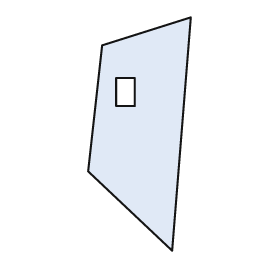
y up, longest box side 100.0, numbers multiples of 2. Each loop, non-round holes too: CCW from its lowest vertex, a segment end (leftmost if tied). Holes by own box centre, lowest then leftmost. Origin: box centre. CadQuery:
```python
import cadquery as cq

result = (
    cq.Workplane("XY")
    .moveTo(14.0, -50.0)
    .lineTo(22.0, 50.0)
    .lineTo(-16.0, 38.0)
    .lineTo(-22.0, -16.0)
    .close()
    .moveTo(-10.0, 12.0)
    .lineTo(-2.0, 12.0)
    .lineTo(-2.0, 24.0)
    .lineTo(-10.0, 24.0)
    .close()
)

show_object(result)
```